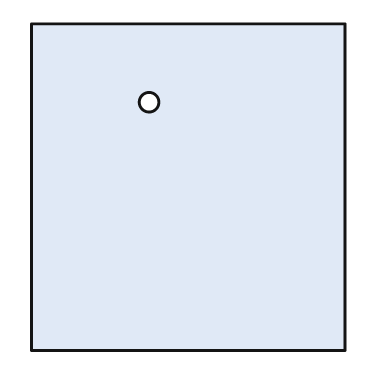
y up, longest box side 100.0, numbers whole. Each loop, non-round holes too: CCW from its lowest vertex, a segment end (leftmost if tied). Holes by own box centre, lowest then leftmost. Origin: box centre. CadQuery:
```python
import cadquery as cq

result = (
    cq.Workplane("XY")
    .moveTo(-48.0, -50.0)
    .lineTo(48.0, -50.0)
    .lineTo(48.0, 50.0)
    .lineTo(-48.0, 50.0)
    .close()
    .moveTo(-12.0, 26.0)
    .circle(3.0)
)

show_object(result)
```